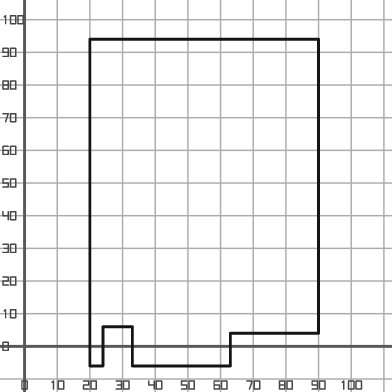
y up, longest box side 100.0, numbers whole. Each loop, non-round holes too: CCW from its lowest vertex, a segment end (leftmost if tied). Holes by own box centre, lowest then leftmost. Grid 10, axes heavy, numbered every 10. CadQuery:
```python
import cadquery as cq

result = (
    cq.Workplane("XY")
    .moveTo(20.0, -6.0)
    .lineTo(24.0, -6.0)
    .lineTo(24.0, 6.0)
    .lineTo(33.0, 6.0)
    .lineTo(33.0, -6.0)
    .lineTo(63.0, -6.0)
    .lineTo(63.0, 4.0)
    .lineTo(90.0, 4.0)
    .lineTo(90.0, 94.0)
    .lineTo(20.0, 94.0)
    .close()
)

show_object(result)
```